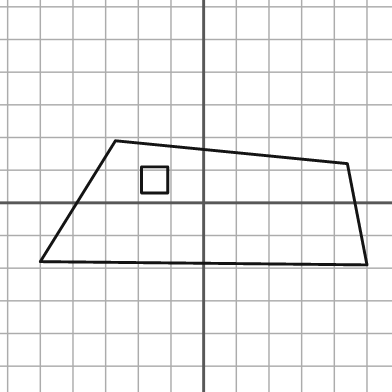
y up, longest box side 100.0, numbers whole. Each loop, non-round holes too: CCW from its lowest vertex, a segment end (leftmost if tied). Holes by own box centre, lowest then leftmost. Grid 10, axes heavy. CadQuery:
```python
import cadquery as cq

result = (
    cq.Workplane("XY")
    .moveTo(50.0, -19.0)
    .lineTo(44.0, 12.0)
    .lineTo(-27.0, 19.0)
    .lineTo(-50.0, -18.0)
    .close()
    .moveTo(-19.0, 3.0)
    .lineTo(-11.0, 3.0)
    .lineTo(-11.0, 11.0)
    .lineTo(-19.0, 11.0)
    .close()
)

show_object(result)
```